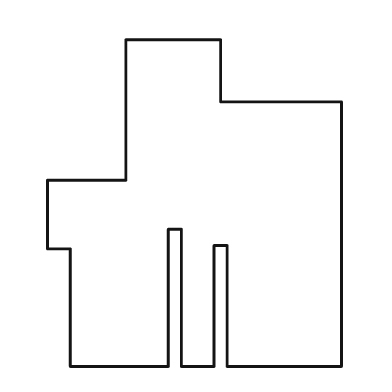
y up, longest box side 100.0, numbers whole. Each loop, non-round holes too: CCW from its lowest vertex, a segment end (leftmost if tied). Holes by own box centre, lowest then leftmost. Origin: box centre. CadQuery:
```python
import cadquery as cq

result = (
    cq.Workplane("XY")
    .moveTo(-38.0, -50.0)
    .lineTo(-8.0, -50.0)
    .lineTo(-8.0, -8.0)
    .lineTo(-4.0, -8.0)
    .lineTo(-4.0, -50.0)
    .lineTo(6.0, -50.0)
    .lineTo(6.0, -13.0)
    .lineTo(10.0, -13.0)
    .lineTo(10.0, -50.0)
    .lineTo(45.0, -50.0)
    .lineTo(45.0, 31.0)
    .lineTo(8.0, 31.0)
    .lineTo(8.0, 50.0)
    .lineTo(-21.0, 50.0)
    .lineTo(-21.0, 7.0)
    .lineTo(-45.0, 7.0)
    .lineTo(-45.0, -14.0)
    .lineTo(-38.0, -14.0)
    .close()
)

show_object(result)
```